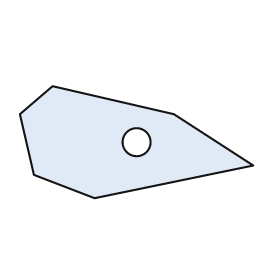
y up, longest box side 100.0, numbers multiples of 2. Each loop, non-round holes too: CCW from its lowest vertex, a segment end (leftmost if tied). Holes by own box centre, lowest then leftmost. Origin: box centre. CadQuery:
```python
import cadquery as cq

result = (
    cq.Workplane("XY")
    .moveTo(-18.0, -24.0)
    .lineTo(50.0, -10.0)
    .lineTo(16.0, 12.0)
    .lineTo(-36.0, 24.0)
    .lineTo(-50.0, 12.0)
    .lineTo(-44.0, -14.0)
    .close()
    .moveTo(0.0, 0.0)
    .circle(6.0)
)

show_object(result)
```